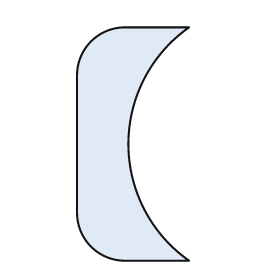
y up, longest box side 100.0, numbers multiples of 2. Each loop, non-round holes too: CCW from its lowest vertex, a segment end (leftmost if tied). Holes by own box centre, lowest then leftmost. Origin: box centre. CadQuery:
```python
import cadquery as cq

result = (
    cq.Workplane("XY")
    .moveTo(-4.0, -50.0)
    .lineTo(24.0, -50.0)
    .threePointArc((-2.0, 0.0), (24.0, 50.0))
    .lineTo(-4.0, 50.0)
    .threePointArc((-18.0, 44.0), (-24.0, 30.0))
    .lineTo(-24.0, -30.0)
    .threePointArc((-18.0, -44.0), (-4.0, -50.0))
    .close()
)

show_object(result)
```